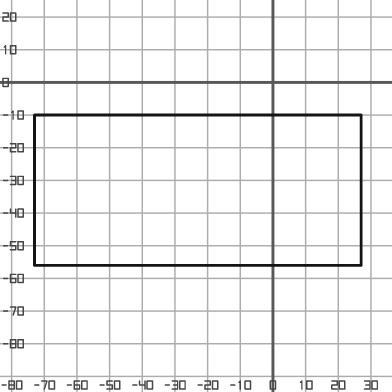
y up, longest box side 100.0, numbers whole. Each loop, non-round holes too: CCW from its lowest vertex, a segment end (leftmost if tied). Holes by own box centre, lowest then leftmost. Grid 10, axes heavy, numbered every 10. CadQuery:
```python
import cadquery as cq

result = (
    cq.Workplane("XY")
    .moveTo(-73.0, -56.0)
    .lineTo(27.0, -56.0)
    .lineTo(27.0, -10.0)
    .lineTo(-73.0, -10.0)
    .close()
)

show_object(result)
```